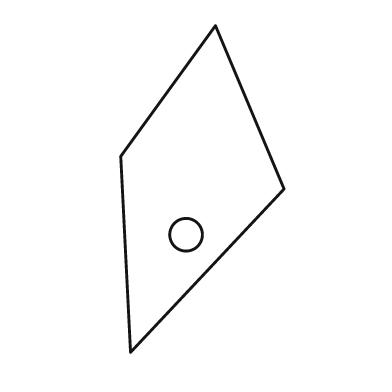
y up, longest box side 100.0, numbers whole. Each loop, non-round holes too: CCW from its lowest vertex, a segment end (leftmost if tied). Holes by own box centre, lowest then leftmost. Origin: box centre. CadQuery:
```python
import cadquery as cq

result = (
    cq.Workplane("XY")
    .moveTo(-22.0, -50.0)
    .lineTo(25.0, 0.0)
    .lineTo(4.0, 50.0)
    .lineTo(-25.0, 10.0)
    .close()
    .moveTo(-5.0, -14.0)
    .circle(5.0)
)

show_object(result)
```